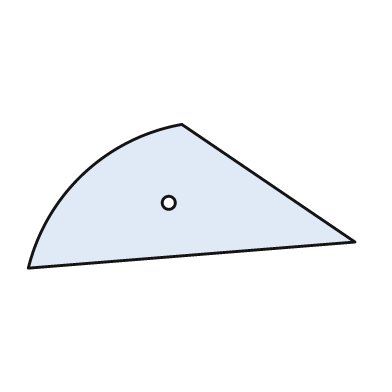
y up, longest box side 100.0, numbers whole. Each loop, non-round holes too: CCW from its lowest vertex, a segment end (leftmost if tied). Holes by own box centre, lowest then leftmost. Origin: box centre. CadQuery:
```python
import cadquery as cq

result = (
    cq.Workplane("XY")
    .moveTo(-50.0, -22.0)
    .lineTo(50.0, -14.0)
    .lineTo(-3.0, 22.0)
    .threePointArc((-33.0, 7.0), (-50.0, -22.0))
    .close()
    .moveTo(-7.0, -2.0)
    .circle(2.0)
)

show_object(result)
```